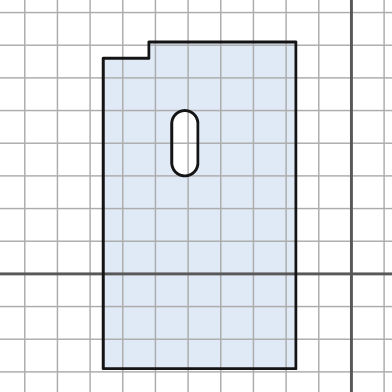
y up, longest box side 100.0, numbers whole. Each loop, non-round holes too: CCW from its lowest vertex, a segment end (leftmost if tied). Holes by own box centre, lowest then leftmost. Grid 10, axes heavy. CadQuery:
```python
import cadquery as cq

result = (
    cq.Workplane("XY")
    .moveTo(-76.0, -29.0)
    .lineTo(-17.0, -29.0)
    .lineTo(-17.0, 71.0)
    .lineTo(-62.0, 71.0)
    .lineTo(-62.0, 66.0)
    .lineTo(-76.0, 66.0)
    .close()
    .moveTo(-55.0, 34.0)
    .threePointArc((-51.0, 30.0), (-47.0, 34.0))
    .lineTo(-47.0, 46.0)
    .threePointArc((-51.0, 50.0), (-55.0, 46.0))
    .close()
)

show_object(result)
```